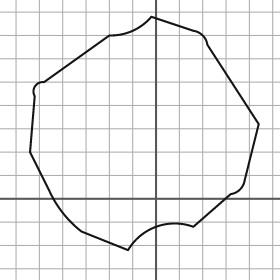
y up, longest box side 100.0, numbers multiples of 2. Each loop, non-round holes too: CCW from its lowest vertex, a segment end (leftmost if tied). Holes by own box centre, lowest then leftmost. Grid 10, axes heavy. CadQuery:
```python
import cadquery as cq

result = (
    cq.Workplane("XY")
    .moveTo(-12.0, -22.0)
    .threePointArc((0.0, -12.0), (16.0, -12.0))
    .lineTo(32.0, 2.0)
    .threePointArc((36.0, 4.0), (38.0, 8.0))
    .lineTo(44.0, 32.0)
    .lineTo(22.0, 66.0)
    .threePointArc((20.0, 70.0), (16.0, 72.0))
    .lineTo(-2.0, 78.0)
    .threePointArc((-10.0, 72.0), (-20.0, 70.0))
    .lineTo(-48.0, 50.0)
    .threePointArc((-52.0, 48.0), (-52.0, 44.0))
    .lineTo(-54.0, 20.0)
    .lineTo(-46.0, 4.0)
    .threePointArc((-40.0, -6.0), (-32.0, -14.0))
    .close()
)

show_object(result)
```